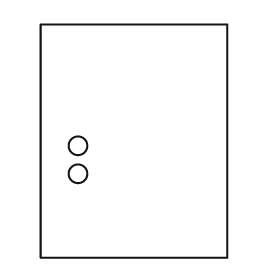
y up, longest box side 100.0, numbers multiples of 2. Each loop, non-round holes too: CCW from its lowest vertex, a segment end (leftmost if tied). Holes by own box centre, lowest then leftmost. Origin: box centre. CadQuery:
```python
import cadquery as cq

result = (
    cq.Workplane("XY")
    .moveTo(-40.0, -50.0)
    .lineTo(40.0, -50.0)
    .lineTo(40.0, 50.0)
    .lineTo(-40.0, 50.0)
    .close()
    .moveTo(-24.0, -14.0)
    .circle(4.0)
    .moveTo(-24.0, -2.0)
    .circle(4.0)
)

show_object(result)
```